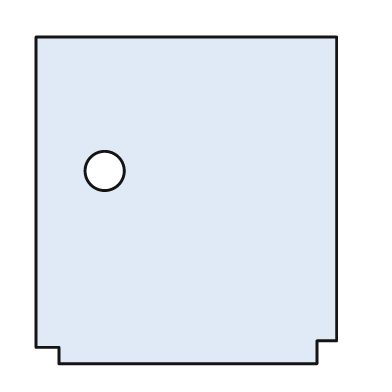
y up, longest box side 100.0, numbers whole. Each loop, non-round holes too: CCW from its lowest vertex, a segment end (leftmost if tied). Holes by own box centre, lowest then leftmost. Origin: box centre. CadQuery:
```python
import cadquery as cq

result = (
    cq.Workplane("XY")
    .moveTo(-39.0, -50.0)
    .lineTo(40.0, -50.0)
    .lineTo(40.0, -43.0)
    .lineTo(46.0, -43.0)
    .lineTo(46.0, 50.0)
    .lineTo(-46.0, 50.0)
    .lineTo(-46.0, -45.0)
    .lineTo(-39.0, -45.0)
    .close()
    .moveTo(-25.0, 9.0)
    .circle(6.0)
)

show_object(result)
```